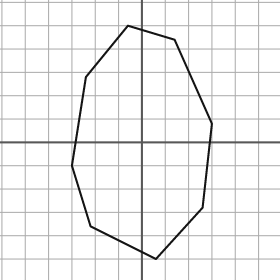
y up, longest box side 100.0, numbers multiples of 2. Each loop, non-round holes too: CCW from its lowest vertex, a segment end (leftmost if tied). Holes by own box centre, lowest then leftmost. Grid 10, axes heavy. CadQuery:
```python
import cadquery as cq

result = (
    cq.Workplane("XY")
    .moveTo(6.0, -50.0)
    .lineTo(26.0, -28.0)
    .lineTo(30.0, 8.0)
    .lineTo(14.0, 44.0)
    .lineTo(-6.0, 50.0)
    .lineTo(-24.0, 28.0)
    .lineTo(-30.0, -10.0)
    .lineTo(-22.0, -36.0)
    .close()
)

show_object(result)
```